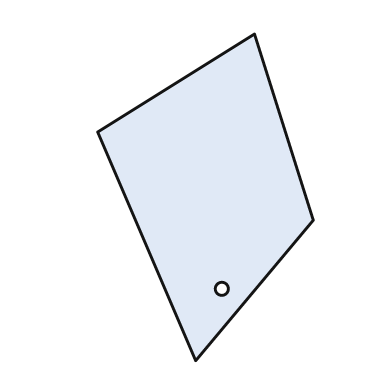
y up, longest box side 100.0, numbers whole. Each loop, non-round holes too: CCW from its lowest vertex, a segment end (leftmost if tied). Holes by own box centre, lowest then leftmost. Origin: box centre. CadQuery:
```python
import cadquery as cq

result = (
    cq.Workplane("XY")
    .moveTo(-3.0, -50.0)
    .lineTo(33.0, -7.0)
    .lineTo(15.0, 50.0)
    .lineTo(-33.0, 20.0)
    .close()
    .moveTo(5.0, -28.0)
    .circle(2.0)
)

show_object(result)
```